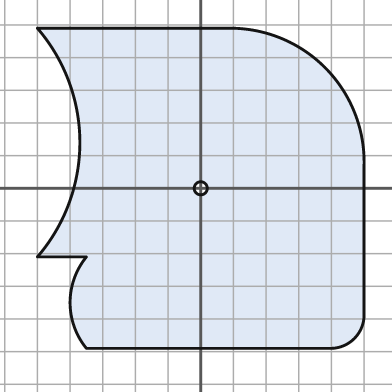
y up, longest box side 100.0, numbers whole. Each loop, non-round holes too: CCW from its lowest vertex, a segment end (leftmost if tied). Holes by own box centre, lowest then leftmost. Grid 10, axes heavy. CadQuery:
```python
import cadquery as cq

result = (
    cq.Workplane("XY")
    .moveTo(-35.0, -49.0)
    .lineTo(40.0, -49.0)
    .threePointArc((47.0, -46.0), (50.0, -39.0))
    .lineTo(50.0, 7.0)
    .threePointArc((38.0, 37.0), (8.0, 49.0))
    .lineTo(-50.0, 49.0)
    .threePointArc((-37.0, 14.0), (-50.0, -21.0))
    .lineTo(-35.0, -21.0)
    .threePointArc((-40.0, -35.0), (-35.0, -49.0))
    .close()
    .moveTo(0.0, 0.0)
    .circle(2.0)
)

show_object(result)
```